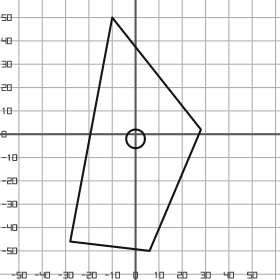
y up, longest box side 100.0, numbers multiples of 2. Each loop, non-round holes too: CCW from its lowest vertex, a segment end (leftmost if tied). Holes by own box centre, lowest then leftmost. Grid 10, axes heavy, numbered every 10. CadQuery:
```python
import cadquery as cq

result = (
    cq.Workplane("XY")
    .moveTo(6.0, -50.0)
    .lineTo(28.0, 2.0)
    .lineTo(-10.0, 50.0)
    .lineTo(-28.0, -46.0)
    .close()
    .moveTo(0.0, -2.0)
    .circle(4.0)
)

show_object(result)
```